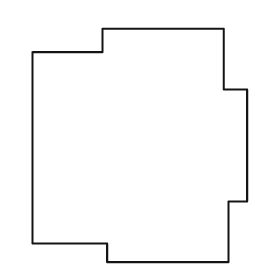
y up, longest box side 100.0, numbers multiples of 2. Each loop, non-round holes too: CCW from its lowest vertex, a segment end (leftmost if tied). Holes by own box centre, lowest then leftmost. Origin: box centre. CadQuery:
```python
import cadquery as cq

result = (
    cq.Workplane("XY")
    .moveTo(-14.0, -50.0)
    .lineTo(38.0, -50.0)
    .lineTo(38.0, -24.0)
    .lineTo(46.0, -24.0)
    .lineTo(46.0, 24.0)
    .lineTo(36.0, 24.0)
    .lineTo(36.0, 50.0)
    .lineTo(-16.0, 50.0)
    .lineTo(-16.0, 40.0)
    .lineTo(-46.0, 40.0)
    .lineTo(-46.0, -42.0)
    .lineTo(-14.0, -42.0)
    .close()
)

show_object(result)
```